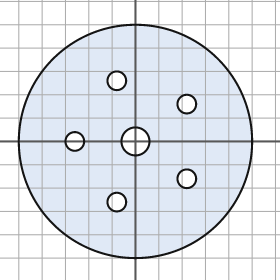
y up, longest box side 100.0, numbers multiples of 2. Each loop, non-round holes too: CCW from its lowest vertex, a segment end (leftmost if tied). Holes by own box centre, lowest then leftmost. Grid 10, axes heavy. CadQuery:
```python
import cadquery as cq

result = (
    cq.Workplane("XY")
    .moveTo(0.0, 0.0)
    .circle(50.0)
    .moveTo(-8.0, -26.0)
    .circle(4.0)
    .moveTo(22.0, -16.0)
    .circle(4.0)
    .moveTo(-26.0, 0.0)
    .circle(4.0)
    .moveTo(0.0, 0.0)
    .circle(6.0)
    .moveTo(22.0, 16.0)
    .circle(4.0)
    .moveTo(-8.0, 26.0)
    .circle(4.0)
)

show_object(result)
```